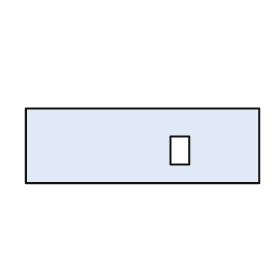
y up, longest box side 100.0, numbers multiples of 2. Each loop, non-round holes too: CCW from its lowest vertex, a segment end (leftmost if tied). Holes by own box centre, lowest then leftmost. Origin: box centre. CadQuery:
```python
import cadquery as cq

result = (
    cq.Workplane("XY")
    .moveTo(-50.0, -16.0)
    .lineTo(50.0, -16.0)
    .lineTo(50.0, 16.0)
    .lineTo(-50.0, 16.0)
    .close()
    .moveTo(12.0, -8.0)
    .lineTo(20.0, -8.0)
    .lineTo(20.0, 4.0)
    .lineTo(12.0, 4.0)
    .close()
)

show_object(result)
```